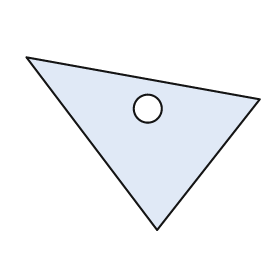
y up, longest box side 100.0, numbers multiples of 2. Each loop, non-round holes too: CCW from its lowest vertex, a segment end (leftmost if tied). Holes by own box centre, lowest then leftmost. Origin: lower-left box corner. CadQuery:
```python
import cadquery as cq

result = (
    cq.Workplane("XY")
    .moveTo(56.0, 0.0)
    .lineTo(100.0, 56.0)
    .lineTo(0.0, 74.0)
    .close()
    .moveTo(52.0, 52.0)
    .circle(6.0)
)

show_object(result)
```